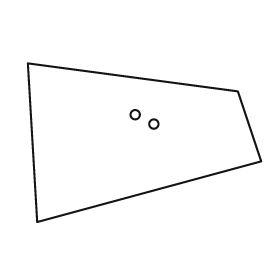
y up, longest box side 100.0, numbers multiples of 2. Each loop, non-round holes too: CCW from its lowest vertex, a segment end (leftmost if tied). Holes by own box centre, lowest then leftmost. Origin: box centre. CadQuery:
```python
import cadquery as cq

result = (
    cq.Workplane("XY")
    .moveTo(-46.0, -34.0)
    .lineTo(50.0, -8.0)
    .lineTo(40.0, 22.0)
    .lineTo(-50.0, 34.0)
    .close()
    .moveTo(4.0, 8.0)
    .circle(2.0)
    .moveTo(-4.0, 12.0)
    .circle(2.0)
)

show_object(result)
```